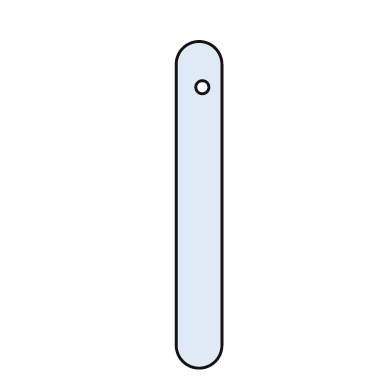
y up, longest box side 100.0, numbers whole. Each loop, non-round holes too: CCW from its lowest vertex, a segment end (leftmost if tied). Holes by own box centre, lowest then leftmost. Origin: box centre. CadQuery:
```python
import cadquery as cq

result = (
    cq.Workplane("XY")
    .moveTo(-7.0, -43.0)
    .threePointArc((0.0, -50.0), (7.0, -43.0))
    .lineTo(7.0, 43.0)
    .threePointArc((0.0, 50.0), (-7.0, 43.0))
    .close()
    .moveTo(1.0, 36.0)
    .circle(2.0)
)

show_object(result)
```